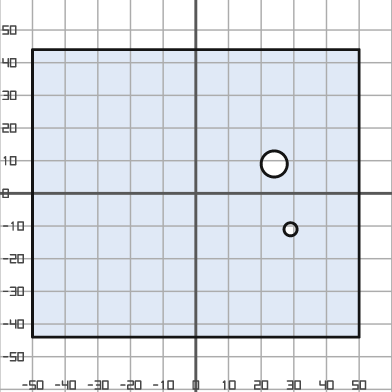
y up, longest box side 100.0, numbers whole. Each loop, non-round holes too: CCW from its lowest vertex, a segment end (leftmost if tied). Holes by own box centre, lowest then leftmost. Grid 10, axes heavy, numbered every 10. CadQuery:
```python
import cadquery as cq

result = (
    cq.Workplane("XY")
    .moveTo(-50.0, -44.0)
    .lineTo(50.0, -44.0)
    .lineTo(50.0, 44.0)
    .lineTo(-50.0, 44.0)
    .close()
    .moveTo(29.0, -11.0)
    .circle(2.0)
    .moveTo(24.0, 9.0)
    .circle(4.0)
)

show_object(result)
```